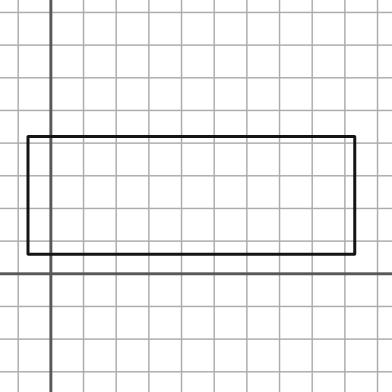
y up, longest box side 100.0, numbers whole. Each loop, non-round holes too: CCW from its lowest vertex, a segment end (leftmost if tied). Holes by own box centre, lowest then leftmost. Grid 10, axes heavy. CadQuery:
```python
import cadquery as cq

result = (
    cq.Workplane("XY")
    .moveTo(-7.0, 6.0)
    .lineTo(93.0, 6.0)
    .lineTo(93.0, 42.0)
    .lineTo(-7.0, 42.0)
    .close()
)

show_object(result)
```